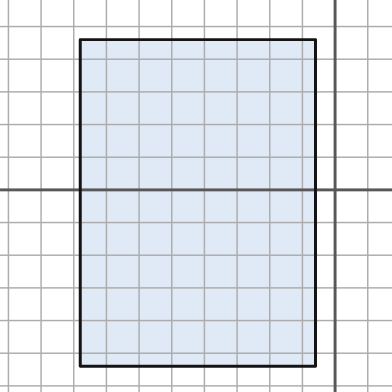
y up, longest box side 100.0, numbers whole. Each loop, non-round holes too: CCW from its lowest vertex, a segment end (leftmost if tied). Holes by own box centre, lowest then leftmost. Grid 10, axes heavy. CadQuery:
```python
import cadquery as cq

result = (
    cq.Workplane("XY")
    .moveTo(-78.0, -54.0)
    .lineTo(-6.0, -54.0)
    .lineTo(-6.0, 46.0)
    .lineTo(-78.0, 46.0)
    .close()
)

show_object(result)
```